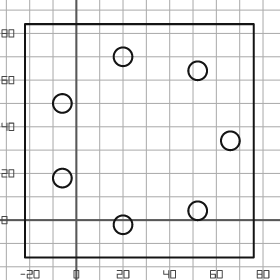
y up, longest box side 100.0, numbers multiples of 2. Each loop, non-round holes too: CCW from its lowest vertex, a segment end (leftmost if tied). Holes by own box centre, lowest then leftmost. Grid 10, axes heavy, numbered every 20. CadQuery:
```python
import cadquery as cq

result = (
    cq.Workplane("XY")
    .moveTo(-22.0, -16.0)
    .lineTo(76.0, -16.0)
    .lineTo(76.0, 84.0)
    .lineTo(-22.0, 84.0)
    .close()
    .moveTo(20.0, -2.0)
    .circle(4.0)
    .moveTo(52.0, 4.0)
    .circle(4.0)
    .moveTo(-6.0, 18.0)
    .circle(4.0)
    .moveTo(66.0, 34.0)
    .circle(4.0)
    .moveTo(-6.0, 50.0)
    .circle(4.0)
    .moveTo(52.0, 64.0)
    .circle(4.0)
    .moveTo(20.0, 70.0)
    .circle(4.0)
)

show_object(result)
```